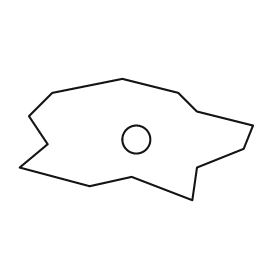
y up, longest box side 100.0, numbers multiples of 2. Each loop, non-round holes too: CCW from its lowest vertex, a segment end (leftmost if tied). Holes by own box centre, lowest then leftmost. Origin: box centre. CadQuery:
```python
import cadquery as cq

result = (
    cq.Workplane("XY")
    .moveTo(24.0, -26.0)
    .lineTo(26.0, -12.0)
    .lineTo(46.0, -4.0)
    .lineTo(50.0, 6.0)
    .lineTo(26.0, 12.0)
    .lineTo(18.0, 20.0)
    .lineTo(-6.0, 26.0)
    .lineTo(-36.0, 20.0)
    .lineTo(-46.0, 10.0)
    .lineTo(-38.0, -2.0)
    .lineTo(-50.0, -12.0)
    .lineTo(-20.0, -20.0)
    .lineTo(-2.0, -16.0)
    .close()
    .moveTo(0.0, 0.0)
    .circle(6.0)
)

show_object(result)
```